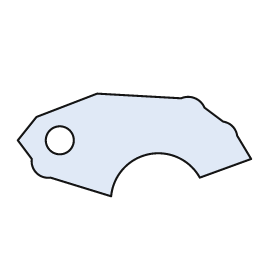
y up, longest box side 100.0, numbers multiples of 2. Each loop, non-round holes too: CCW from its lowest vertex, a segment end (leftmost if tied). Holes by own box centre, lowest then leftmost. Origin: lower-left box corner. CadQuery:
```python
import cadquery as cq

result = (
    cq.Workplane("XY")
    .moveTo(40.0, 0.0)
    .threePointArc((56.0, 18.0), (78.0, 8.0))
    .lineTo(100.0, 16.0)
    .lineTo(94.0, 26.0)
    .threePointArc((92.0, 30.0), (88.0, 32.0))
    .lineTo(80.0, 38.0)
    .threePointArc((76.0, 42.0), (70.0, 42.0))
    .lineTo(34.0, 44.0)
    .lineTo(8.0, 34.0)
    .lineTo(0.0, 24.0)
    .lineTo(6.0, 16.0)
    .threePointArc((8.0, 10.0), (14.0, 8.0))
    .close()
    .moveTo(18.0, 24.0)
    .circle(6.0)
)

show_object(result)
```